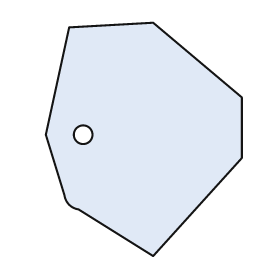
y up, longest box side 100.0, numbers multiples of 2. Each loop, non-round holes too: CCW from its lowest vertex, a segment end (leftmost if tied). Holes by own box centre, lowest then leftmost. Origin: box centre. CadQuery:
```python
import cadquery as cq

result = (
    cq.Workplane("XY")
    .moveTo(4.0, -50.0)
    .lineTo(42.0, -8.0)
    .lineTo(42.0, 18.0)
    .lineTo(4.0, 50.0)
    .lineTo(-32.0, 48.0)
    .lineTo(-42.0, 2.0)
    .lineTo(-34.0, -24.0)
    .threePointArc((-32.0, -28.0), (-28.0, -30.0))
    .close()
    .moveTo(-26.0, 2.0)
    .circle(4.0)
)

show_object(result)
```